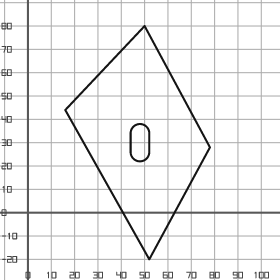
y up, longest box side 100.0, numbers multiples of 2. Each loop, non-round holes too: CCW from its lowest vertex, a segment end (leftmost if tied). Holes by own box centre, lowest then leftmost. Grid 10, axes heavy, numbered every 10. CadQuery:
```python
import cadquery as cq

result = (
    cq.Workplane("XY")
    .moveTo(52.0, -20.0)
    .lineTo(78.0, 28.0)
    .lineTo(50.0, 80.0)
    .lineTo(16.0, 44.0)
    .close()
    .moveTo(44.0, 26.0)
    .threePointArc((48.0, 22.0), (52.0, 26.0))
    .lineTo(52.0, 34.0)
    .threePointArc((48.0, 38.0), (44.0, 34.0))
    .close()
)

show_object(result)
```